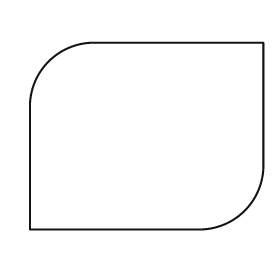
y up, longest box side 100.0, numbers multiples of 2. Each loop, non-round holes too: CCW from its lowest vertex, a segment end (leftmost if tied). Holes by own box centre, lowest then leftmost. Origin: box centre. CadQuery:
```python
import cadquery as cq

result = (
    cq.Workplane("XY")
    .moveTo(-50.0, -40.0)
    .lineTo(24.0, -40.0)
    .threePointArc((42.0, -32.0), (50.0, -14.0))
    .lineTo(50.0, 40.0)
    .lineTo(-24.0, 40.0)
    .threePointArc((-42.0, 32.0), (-50.0, 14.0))
    .close()
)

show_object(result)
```